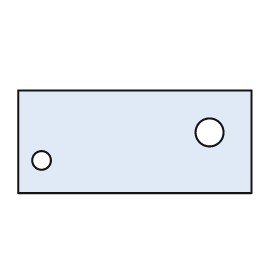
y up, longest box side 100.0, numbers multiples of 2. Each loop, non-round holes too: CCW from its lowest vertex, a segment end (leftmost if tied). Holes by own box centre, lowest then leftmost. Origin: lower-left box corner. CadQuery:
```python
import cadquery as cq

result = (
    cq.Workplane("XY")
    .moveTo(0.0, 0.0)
    .lineTo(100.0, 0.0)
    .lineTo(100.0, 44.0)
    .lineTo(0.0, 44.0)
    .close()
    .moveTo(10.0, 14.0)
    .circle(4.0)
    .moveTo(82.0, 26.0)
    .circle(6.0)
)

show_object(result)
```